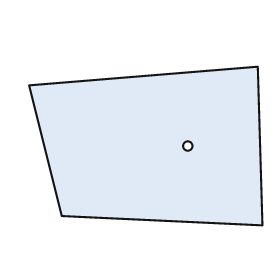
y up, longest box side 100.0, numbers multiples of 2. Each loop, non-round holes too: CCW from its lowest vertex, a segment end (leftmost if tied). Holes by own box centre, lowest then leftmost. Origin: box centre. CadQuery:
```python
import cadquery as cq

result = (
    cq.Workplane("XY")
    .moveTo(50.0, -34.0)
    .lineTo(48.0, 34.0)
    .lineTo(-50.0, 26.0)
    .lineTo(-36.0, -30.0)
    .close()
    .moveTo(18.0, 0.0)
    .circle(2.0)
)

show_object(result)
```